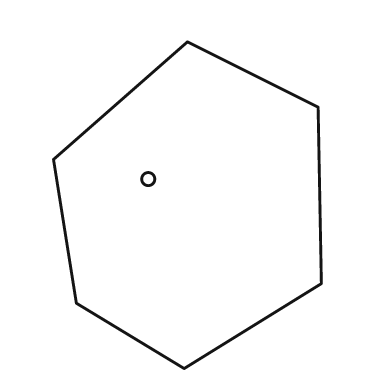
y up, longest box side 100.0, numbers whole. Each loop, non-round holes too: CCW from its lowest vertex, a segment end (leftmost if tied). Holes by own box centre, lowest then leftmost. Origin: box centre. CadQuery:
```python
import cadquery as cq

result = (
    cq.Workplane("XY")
    .moveTo(-1.0, -50.0)
    .lineTo(41.0, -24.0)
    .lineTo(40.0, 30.0)
    .lineTo(0.0, 50.0)
    .lineTo(-41.0, 14.0)
    .lineTo(-34.0, -30.0)
    .close()
    .moveTo(-12.0, 8.0)
    .circle(2.0)
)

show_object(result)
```